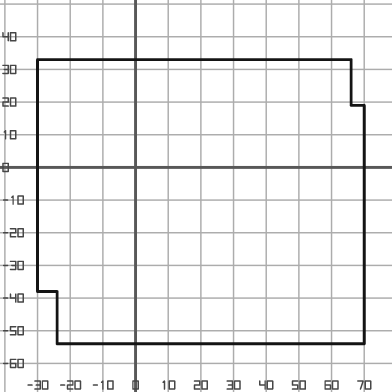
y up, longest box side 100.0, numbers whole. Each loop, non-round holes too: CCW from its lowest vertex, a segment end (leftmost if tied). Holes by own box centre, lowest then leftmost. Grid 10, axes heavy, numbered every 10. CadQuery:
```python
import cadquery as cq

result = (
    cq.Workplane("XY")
    .moveTo(-24.0, -54.0)
    .lineTo(70.0, -54.0)
    .lineTo(70.0, 19.0)
    .lineTo(66.0, 19.0)
    .lineTo(66.0, 33.0)
    .lineTo(-30.0, 33.0)
    .lineTo(-30.0, -38.0)
    .lineTo(-24.0, -38.0)
    .close()
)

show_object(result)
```